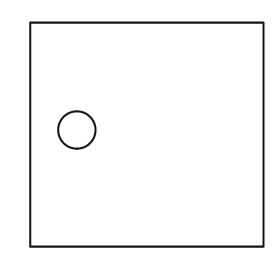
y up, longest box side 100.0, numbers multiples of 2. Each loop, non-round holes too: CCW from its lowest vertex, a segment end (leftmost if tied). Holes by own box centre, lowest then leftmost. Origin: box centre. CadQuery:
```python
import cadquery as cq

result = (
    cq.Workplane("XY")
    .moveTo(-50.0, -48.0)
    .lineTo(50.0, -48.0)
    .lineTo(50.0, 48.0)
    .lineTo(-50.0, 48.0)
    .close()
    .moveTo(-30.0, 2.0)
    .circle(8.0)
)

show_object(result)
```